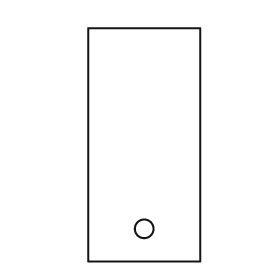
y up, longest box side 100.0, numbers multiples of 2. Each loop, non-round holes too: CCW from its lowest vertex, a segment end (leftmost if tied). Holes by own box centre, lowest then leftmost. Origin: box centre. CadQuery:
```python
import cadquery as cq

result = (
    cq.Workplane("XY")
    .moveTo(-24.0, -50.0)
    .lineTo(24.0, -50.0)
    .lineTo(24.0, 50.0)
    .lineTo(-24.0, 50.0)
    .close()
    .moveTo(0.0, -36.0)
    .circle(4.0)
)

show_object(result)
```